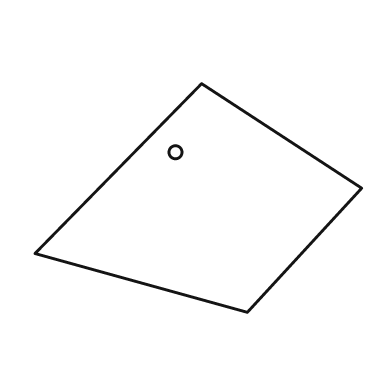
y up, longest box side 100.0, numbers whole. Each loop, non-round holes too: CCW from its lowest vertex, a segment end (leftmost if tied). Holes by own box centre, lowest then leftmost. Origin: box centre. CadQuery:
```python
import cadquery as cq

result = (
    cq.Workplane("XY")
    .moveTo(15.0, -35.0)
    .lineTo(50.0, 3.0)
    .lineTo(1.0, 35.0)
    .lineTo(-50.0, -17.0)
    .close()
    .moveTo(-7.0, 14.0)
    .circle(2.0)
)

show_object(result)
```